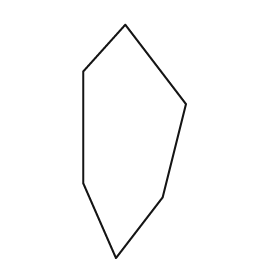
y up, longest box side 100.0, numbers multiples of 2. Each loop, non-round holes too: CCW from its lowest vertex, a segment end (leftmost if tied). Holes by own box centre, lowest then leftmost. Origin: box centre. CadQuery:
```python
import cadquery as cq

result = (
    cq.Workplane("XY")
    .moveTo(-8.0, -50.0)
    .lineTo(12.0, -24.0)
    .lineTo(22.0, 16.0)
    .lineTo(-4.0, 50.0)
    .lineTo(-22.0, 30.0)
    .lineTo(-22.0, -18.0)
    .close()
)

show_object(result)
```